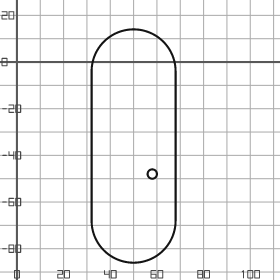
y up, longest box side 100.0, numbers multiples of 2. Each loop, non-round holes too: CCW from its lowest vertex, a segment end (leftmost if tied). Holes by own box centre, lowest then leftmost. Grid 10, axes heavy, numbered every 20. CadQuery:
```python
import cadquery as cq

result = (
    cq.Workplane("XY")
    .moveTo(32.0, -68.0)
    .threePointArc((50.0, -86.0), (68.0, -68.0))
    .lineTo(68.0, -4.0)
    .threePointArc((50.0, 14.0), (32.0, -4.0))
    .close()
    .moveTo(58.0, -48.0)
    .circle(2.0)
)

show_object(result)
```